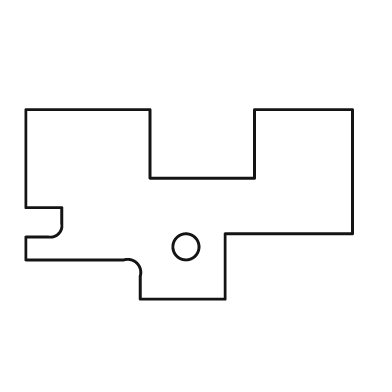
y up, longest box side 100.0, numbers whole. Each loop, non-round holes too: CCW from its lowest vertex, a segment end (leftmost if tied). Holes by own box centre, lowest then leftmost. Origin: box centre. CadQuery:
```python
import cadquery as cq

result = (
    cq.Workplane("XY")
    .moveTo(-15.0, -29.0)
    .lineTo(11.0, -29.0)
    .lineTo(11.0, -9.0)
    .lineTo(50.0, -9.0)
    .lineTo(50.0, 29.0)
    .lineTo(20.0, 29.0)
    .lineTo(20.0, 8.0)
    .lineTo(-12.0, 8.0)
    .lineTo(-12.0, 29.0)
    .lineTo(-50.0, 29.0)
    .lineTo(-50.0, -1.0)
    .lineTo(-39.0, -1.0)
    .lineTo(-39.0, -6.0)
    .threePointArc((-40.0, -9.0), (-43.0, -10.0))
    .lineTo(-50.0, -10.0)
    .lineTo(-50.0, -17.0)
    .lineTo(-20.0, -17.0)
    .threePointArc((-16.0, -18.0), (-15.0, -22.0))
    .close()
    .moveTo(-1.0, -13.0)
    .circle(4.0)
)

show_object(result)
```